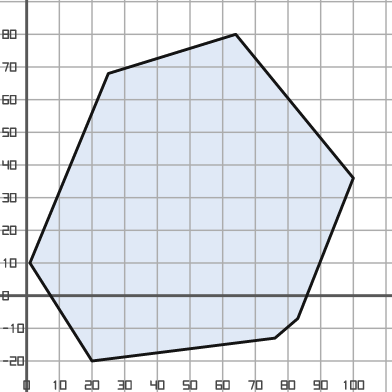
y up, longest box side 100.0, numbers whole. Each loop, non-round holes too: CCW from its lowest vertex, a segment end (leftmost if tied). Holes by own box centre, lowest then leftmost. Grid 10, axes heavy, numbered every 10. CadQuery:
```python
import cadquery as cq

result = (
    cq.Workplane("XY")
    .moveTo(20.0, -20.0)
    .lineTo(76.0, -13.0)
    .lineTo(83.0, -7.0)
    .lineTo(100.0, 36.0)
    .lineTo(64.0, 80.0)
    .lineTo(25.0, 68.0)
    .lineTo(1.0, 10.0)
    .close()
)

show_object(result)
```